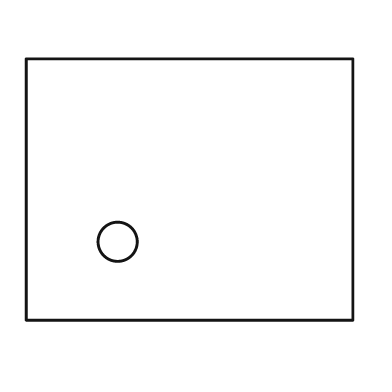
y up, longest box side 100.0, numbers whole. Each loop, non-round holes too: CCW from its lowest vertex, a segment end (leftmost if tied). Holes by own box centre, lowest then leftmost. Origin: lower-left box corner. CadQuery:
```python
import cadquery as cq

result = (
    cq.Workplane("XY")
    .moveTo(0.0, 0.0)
    .lineTo(100.0, 0.0)
    .lineTo(100.0, 80.0)
    .lineTo(0.0, 80.0)
    .close()
    .moveTo(28.0, 24.0)
    .circle(6.0)
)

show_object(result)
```